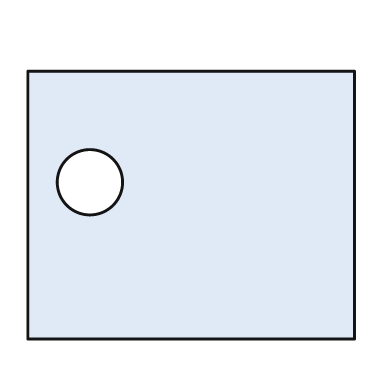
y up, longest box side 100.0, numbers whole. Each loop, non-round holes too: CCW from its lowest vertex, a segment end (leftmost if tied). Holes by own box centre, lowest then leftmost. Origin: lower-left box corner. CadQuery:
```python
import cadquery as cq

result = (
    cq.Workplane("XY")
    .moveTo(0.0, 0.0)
    .lineTo(100.0, 0.0)
    .lineTo(100.0, 82.0)
    .lineTo(0.0, 82.0)
    .close()
    .moveTo(19.0, 48.0)
    .circle(10.0)
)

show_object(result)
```